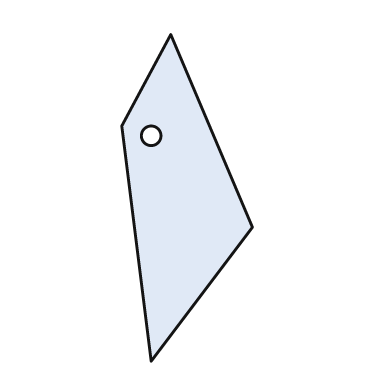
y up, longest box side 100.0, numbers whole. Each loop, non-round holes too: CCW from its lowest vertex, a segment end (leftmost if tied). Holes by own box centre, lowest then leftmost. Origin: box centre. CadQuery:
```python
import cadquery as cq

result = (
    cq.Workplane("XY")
    .moveTo(-11.0, -50.0)
    .lineTo(20.0, -9.0)
    .lineTo(-5.0, 50.0)
    .lineTo(-20.0, 22.0)
    .close()
    .moveTo(-11.0, 19.0)
    .circle(3.0)
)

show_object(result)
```